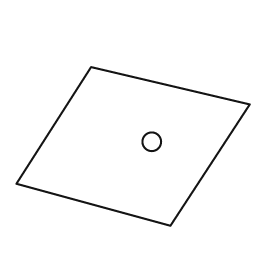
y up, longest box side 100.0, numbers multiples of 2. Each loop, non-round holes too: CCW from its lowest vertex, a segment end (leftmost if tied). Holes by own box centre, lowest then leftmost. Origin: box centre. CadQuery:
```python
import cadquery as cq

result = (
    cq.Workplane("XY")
    .moveTo(16.0, -34.0)
    .lineTo(50.0, 18.0)
    .lineTo(-18.0, 34.0)
    .lineTo(-50.0, -16.0)
    .close()
    .moveTo(8.0, 2.0)
    .circle(4.0)
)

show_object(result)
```